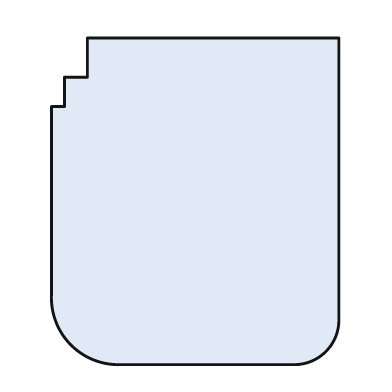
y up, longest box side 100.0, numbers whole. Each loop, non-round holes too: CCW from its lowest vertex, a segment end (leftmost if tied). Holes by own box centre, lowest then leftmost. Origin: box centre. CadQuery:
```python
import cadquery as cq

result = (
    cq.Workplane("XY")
    .moveTo(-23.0, -50.0)
    .lineTo(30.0, -50.0)
    .threePointArc((40.0, -46.0), (44.0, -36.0))
    .lineTo(44.0, 50.0)
    .lineTo(-33.0, 50.0)
    .lineTo(-33.0, 38.0)
    .lineTo(-40.0, 38.0)
    .lineTo(-40.0, 29.0)
    .lineTo(-44.0, 29.0)
    .lineTo(-44.0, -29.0)
    .threePointArc((-38.0, -44.0), (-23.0, -50.0))
    .close()
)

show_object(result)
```